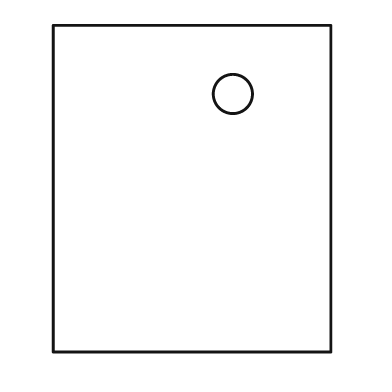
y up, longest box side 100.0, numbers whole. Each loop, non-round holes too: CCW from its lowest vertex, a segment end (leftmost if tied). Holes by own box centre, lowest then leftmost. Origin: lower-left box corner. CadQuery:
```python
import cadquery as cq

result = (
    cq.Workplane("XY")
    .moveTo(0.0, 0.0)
    .lineTo(85.0, 0.0)
    .lineTo(85.0, 100.0)
    .lineTo(0.0, 100.0)
    .close()
    .moveTo(55.0, 79.0)
    .circle(6.0)
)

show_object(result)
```